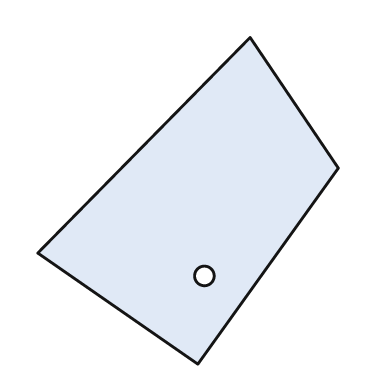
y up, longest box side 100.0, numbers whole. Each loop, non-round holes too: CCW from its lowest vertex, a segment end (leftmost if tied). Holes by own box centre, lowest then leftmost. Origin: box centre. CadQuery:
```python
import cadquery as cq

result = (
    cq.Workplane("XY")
    .moveTo(3.0, -50.0)
    .lineTo(46.0, 10.0)
    .lineTo(19.0, 50.0)
    .lineTo(-46.0, -16.0)
    .close()
    .moveTo(5.0, -23.0)
    .circle(3.0)
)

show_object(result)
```